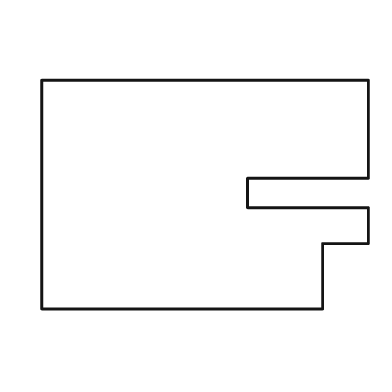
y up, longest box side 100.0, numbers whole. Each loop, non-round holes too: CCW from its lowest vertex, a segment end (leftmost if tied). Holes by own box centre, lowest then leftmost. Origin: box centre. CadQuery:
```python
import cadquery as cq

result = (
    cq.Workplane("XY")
    .moveTo(-50.0, -35.0)
    .lineTo(36.0, -35.0)
    .lineTo(36.0, -15.0)
    .lineTo(50.0, -15.0)
    .lineTo(50.0, -4.0)
    .lineTo(13.0, -4.0)
    .lineTo(13.0, 5.0)
    .lineTo(50.0, 5.0)
    .lineTo(50.0, 35.0)
    .lineTo(-50.0, 35.0)
    .close()
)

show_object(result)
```